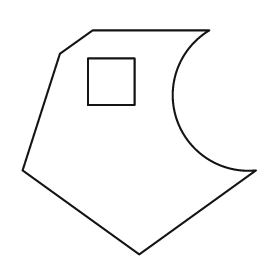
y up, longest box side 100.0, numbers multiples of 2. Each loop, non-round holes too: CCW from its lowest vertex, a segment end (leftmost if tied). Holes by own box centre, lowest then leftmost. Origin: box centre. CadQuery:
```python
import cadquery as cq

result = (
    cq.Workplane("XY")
    .moveTo(0.0, -48.0)
    .lineTo(50.0, -12.0)
    .threePointArc((16.0, 10.0), (30.0, 48.0))
    .lineTo(-20.0, 48.0)
    .lineTo(-34.0, 38.0)
    .lineTo(-50.0, -12.0)
    .close()
    .moveTo(-22.0, 16.0)
    .lineTo(-2.0, 16.0)
    .lineTo(-2.0, 36.0)
    .lineTo(-22.0, 36.0)
    .close()
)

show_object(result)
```